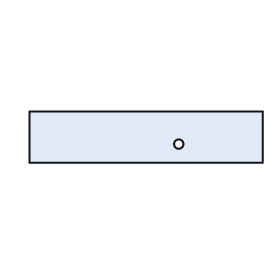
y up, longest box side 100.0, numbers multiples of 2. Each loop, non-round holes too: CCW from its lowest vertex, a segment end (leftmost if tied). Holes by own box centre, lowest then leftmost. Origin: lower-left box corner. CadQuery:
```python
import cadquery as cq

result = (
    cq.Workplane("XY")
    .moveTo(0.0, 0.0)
    .lineTo(100.0, 0.0)
    .lineTo(100.0, 22.0)
    .lineTo(0.0, 22.0)
    .close()
    .moveTo(64.0, 8.0)
    .circle(2.0)
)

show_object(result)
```